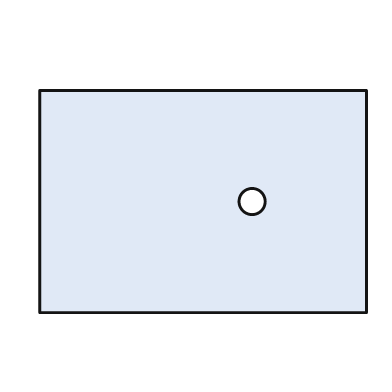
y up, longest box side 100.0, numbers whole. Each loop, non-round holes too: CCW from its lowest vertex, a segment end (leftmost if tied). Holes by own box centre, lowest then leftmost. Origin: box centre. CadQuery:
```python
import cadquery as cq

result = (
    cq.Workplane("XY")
    .moveTo(-50.0, -34.0)
    .lineTo(50.0, -34.0)
    .lineTo(50.0, 34.0)
    .lineTo(-50.0, 34.0)
    .close()
    .moveTo(15.0, 0.0)
    .circle(4.0)
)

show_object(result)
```